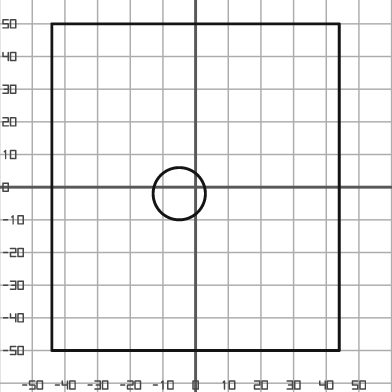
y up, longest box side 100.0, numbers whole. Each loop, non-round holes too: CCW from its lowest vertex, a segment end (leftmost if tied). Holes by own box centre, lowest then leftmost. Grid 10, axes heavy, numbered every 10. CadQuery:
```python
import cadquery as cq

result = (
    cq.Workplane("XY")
    .moveTo(-44.0, -50.0)
    .lineTo(44.0, -50.0)
    .lineTo(44.0, 50.0)
    .lineTo(-44.0, 50.0)
    .close()
    .moveTo(-5.0, -2.0)
    .circle(8.0)
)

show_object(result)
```